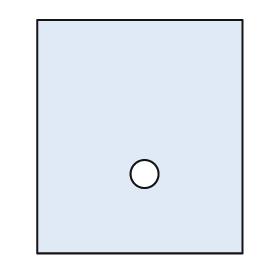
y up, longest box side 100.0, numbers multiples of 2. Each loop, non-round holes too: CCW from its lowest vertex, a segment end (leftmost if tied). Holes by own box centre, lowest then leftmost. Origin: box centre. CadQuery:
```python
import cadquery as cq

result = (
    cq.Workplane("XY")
    .moveTo(-44.0, -50.0)
    .lineTo(44.0, -50.0)
    .lineTo(44.0, 50.0)
    .lineTo(-44.0, 50.0)
    .close()
    .moveTo(2.0, -16.0)
    .circle(6.0)
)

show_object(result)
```